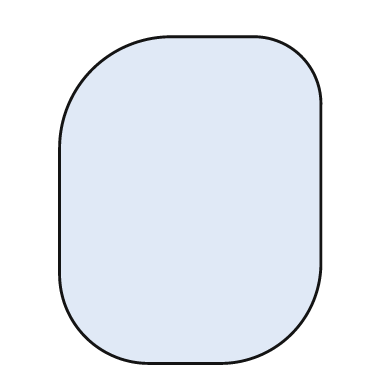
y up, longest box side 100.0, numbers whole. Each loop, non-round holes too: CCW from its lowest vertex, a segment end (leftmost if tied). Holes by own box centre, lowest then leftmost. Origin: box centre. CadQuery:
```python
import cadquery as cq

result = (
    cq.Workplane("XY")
    .moveTo(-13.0, -50.0)
    .lineTo(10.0, -50.0)
    .threePointArc((31.0, -41.0), (40.0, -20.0))
    .lineTo(40.0, 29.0)
    .threePointArc((34.0, 44.0), (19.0, 50.0))
    .lineTo(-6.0, 50.0)
    .threePointArc((-30.0, 40.0), (-40.0, 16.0))
    .lineTo(-40.0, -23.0)
    .threePointArc((-32.0, -42.0), (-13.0, -50.0))
    .close()
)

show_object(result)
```